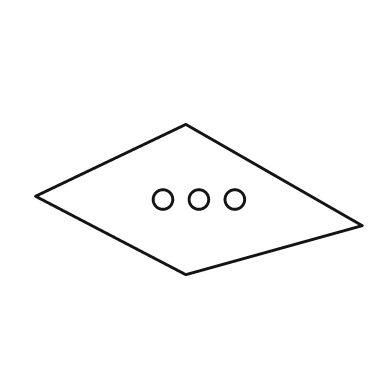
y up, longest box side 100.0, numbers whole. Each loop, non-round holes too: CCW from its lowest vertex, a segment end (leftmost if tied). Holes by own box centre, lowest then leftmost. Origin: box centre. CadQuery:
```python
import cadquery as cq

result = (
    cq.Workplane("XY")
    .moveTo(-4.0, -23.0)
    .lineTo(50.0, -8.0)
    .lineTo(-4.0, 23.0)
    .lineTo(-50.0, 1.0)
    .close()
    .moveTo(-11.0, 0.0)
    .circle(3.0)
    .moveTo(0.0, 0.0)
    .circle(3.0)
    .moveTo(11.0, 0.0)
    .circle(3.0)
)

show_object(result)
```